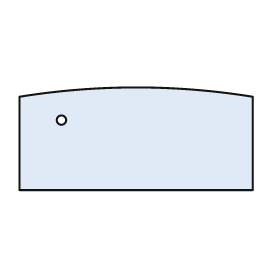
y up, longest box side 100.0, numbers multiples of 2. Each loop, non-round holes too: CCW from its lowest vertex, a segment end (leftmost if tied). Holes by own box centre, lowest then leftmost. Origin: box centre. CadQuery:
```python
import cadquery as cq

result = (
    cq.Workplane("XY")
    .moveTo(-50.0, -22.0)
    .lineTo(50.0, -22.0)
    .lineTo(50.0, 18.0)
    .threePointArc((0.0, 22.0), (-50.0, 18.0))
    .close()
    .moveTo(-32.0, 8.0)
    .circle(2.0)
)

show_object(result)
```